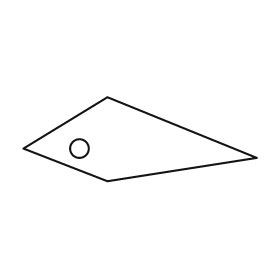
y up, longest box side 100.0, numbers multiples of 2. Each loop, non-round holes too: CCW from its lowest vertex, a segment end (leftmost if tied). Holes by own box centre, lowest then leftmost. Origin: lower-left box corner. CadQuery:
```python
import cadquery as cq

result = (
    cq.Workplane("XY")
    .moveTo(36.0, 0.0)
    .lineTo(100.0, 10.0)
    .lineTo(36.0, 36.0)
    .lineTo(0.0, 14.0)
    .close()
    .moveTo(24.0, 14.0)
    .circle(4.0)
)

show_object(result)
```